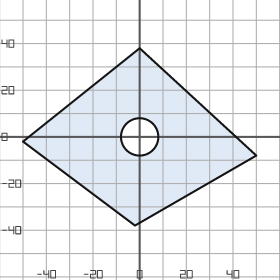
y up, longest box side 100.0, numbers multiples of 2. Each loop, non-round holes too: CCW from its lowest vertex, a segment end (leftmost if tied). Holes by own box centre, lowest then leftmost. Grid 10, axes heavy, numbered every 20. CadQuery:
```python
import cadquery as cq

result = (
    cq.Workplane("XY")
    .moveTo(-2.0, -38.0)
    .lineTo(50.0, -8.0)
    .lineTo(0.0, 38.0)
    .lineTo(-50.0, -2.0)
    .close()
    .moveTo(0.0, 0.0)
    .circle(8.0)
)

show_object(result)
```